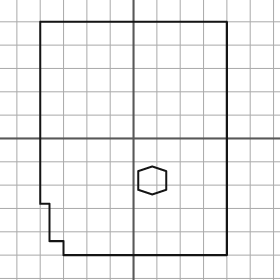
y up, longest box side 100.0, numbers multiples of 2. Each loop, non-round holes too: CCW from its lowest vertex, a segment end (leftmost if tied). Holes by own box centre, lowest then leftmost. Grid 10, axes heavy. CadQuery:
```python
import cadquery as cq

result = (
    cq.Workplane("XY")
    .moveTo(-30.0, -50.0)
    .lineTo(40.0, -50.0)
    .lineTo(40.0, 50.0)
    .lineTo(-40.0, 50.0)
    .lineTo(-40.0, -28.0)
    .lineTo(-36.0, -28.0)
    .lineTo(-36.0, -44.0)
    .lineTo(-30.0, -44.0)
    .close()
    .moveTo(8.0, -24.0)
    .lineTo(14.0, -22.0)
    .lineTo(14.0, -14.0)
    .lineTo(8.0, -12.0)
    .lineTo(2.0, -14.0)
    .lineTo(2.0, -22.0)
    .close()
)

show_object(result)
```